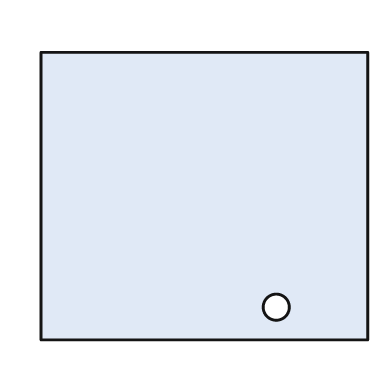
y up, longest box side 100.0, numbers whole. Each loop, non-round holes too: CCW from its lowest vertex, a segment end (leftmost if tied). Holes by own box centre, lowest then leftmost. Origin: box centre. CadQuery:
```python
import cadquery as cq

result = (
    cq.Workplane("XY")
    .moveTo(-50.0, -44.0)
    .lineTo(50.0, -44.0)
    .lineTo(50.0, 44.0)
    .lineTo(-50.0, 44.0)
    .close()
    .moveTo(22.0, -34.0)
    .circle(4.0)
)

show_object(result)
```